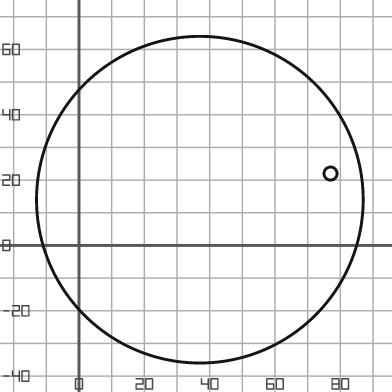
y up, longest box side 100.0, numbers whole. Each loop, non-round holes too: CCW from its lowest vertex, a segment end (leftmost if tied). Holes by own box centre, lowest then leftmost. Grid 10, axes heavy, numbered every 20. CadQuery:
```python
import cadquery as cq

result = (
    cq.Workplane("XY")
    .moveTo(37.0, 14.0)
    .circle(50.0)
    .moveTo(77.0, 22.0)
    .circle(2.0)
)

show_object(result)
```